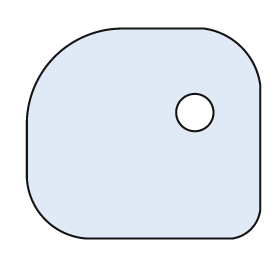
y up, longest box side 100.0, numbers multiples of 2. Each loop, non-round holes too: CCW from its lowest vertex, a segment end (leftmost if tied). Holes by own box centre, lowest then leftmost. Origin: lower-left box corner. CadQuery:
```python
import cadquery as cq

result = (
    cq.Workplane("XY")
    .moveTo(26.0, 0.0)
    .lineTo(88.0, 0.0)
    .threePointArc((96.0, 4.0), (100.0, 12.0))
    .lineTo(100.0, 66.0)
    .threePointArc((92.0, 82.0), (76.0, 90.0))
    .lineTo(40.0, 90.0)
    .threePointArc((12.0, 78.0), (0.0, 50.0))
    .lineTo(0.0, 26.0)
    .threePointArc((8.0, 8.0), (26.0, 0.0))
    .close()
    .moveTo(72.0, 54.0)
    .circle(8.0)
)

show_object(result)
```